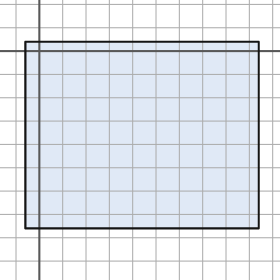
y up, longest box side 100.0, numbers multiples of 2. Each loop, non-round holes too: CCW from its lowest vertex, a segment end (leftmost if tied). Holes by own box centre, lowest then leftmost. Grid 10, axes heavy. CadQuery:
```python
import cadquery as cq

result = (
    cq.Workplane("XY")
    .moveTo(-6.0, -76.0)
    .lineTo(94.0, -76.0)
    .lineTo(94.0, 4.0)
    .lineTo(-6.0, 4.0)
    .close()
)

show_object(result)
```